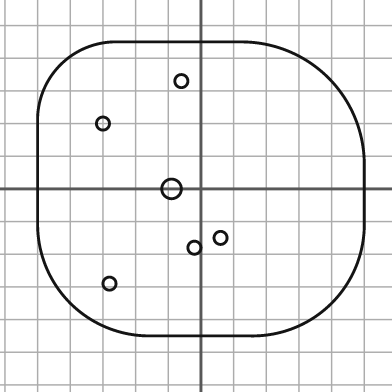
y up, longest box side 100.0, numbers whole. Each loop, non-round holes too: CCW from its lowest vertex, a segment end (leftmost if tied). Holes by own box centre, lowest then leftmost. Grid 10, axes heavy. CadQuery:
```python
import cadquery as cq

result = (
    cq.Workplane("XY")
    .moveTo(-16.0, -45.0)
    .lineTo(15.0, -45.0)
    .threePointArc((40.0, -35.0), (50.0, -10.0))
    .lineTo(50.0, 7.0)
    .threePointArc((39.0, 34.0), (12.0, 45.0))
    .lineTo(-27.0, 45.0)
    .threePointArc((-43.0, 38.0), (-50.0, 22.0))
    .lineTo(-50.0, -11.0)
    .threePointArc((-40.0, -35.0), (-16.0, -45.0))
    .close()
    .moveTo(-28.0, -29.0)
    .circle(2.0)
    .moveTo(-2.0, -18.0)
    .circle(2.0)
    .moveTo(6.0, -15.0)
    .circle(2.0)
    .moveTo(-9.0, 0.0)
    .circle(3.0)
    .moveTo(-30.0, 20.0)
    .circle(2.0)
    .moveTo(-6.0, 33.0)
    .circle(2.0)
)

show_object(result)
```